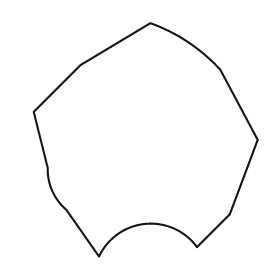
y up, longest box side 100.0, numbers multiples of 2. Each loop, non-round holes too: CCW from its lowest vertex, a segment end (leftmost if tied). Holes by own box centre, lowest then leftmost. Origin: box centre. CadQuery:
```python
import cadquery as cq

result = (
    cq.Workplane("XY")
    .moveTo(-20.0, -50.0)
    .threePointArc((0.0, -36.0), (22.0, -46.0))
    .lineTo(36.0, -32.0)
    .lineTo(48.0, 0.0)
    .lineTo(32.0, 30.0)
    .threePointArc((18.0, 42.0), (2.0, 50.0))
    .lineTo(-28.0, 32.0)
    .lineTo(-48.0, 12.0)
    .lineTo(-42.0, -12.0)
    .threePointArc((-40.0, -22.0), (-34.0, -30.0))
    .close()
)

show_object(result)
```